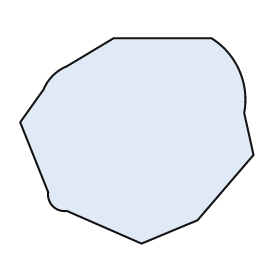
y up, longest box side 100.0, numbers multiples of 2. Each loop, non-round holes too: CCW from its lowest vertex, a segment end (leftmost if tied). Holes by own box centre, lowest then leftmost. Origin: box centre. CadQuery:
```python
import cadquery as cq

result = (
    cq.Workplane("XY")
    .moveTo(2.0, -44.0)
    .lineTo(26.0, -34.0)
    .lineTo(50.0, -6.0)
    .lineTo(46.0, 12.0)
    .threePointArc((44.0, 30.0), (32.0, 44.0))
    .lineTo(-10.0, 44.0)
    .lineTo(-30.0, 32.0)
    .threePointArc((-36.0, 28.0), (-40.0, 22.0))
    .lineTo(-50.0, 8.0)
    .lineTo(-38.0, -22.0)
    .threePointArc((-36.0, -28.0), (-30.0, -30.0))
    .close()
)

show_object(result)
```